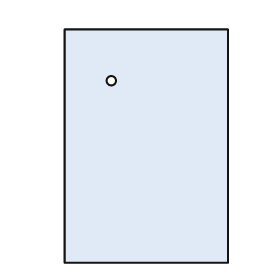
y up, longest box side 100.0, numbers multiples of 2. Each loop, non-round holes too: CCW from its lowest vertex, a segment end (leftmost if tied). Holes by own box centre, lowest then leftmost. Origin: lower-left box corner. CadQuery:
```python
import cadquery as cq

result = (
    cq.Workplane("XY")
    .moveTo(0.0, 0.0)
    .lineTo(70.0, 0.0)
    .lineTo(70.0, 100.0)
    .lineTo(0.0, 100.0)
    .close()
    .moveTo(20.0, 78.0)
    .circle(2.0)
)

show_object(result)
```